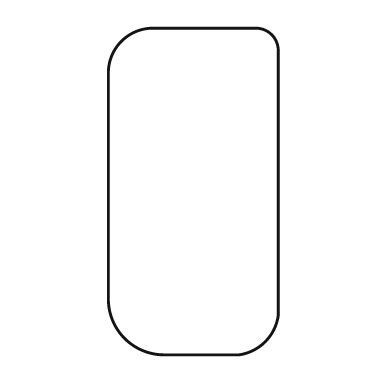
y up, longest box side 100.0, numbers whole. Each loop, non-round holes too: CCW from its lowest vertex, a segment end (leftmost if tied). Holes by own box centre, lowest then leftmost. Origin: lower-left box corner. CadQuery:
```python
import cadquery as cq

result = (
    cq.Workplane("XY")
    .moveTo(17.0, 0.0)
    .lineTo(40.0, 0.0)
    .threePointArc((48.0, 4.0), (52.0, 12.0))
    .lineTo(52.0, 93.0)
    .threePointArc((50.0, 98.0), (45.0, 100.0))
    .lineTo(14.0, 100.0)
    .threePointArc((4.0, 96.0), (0.0, 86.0))
    .lineTo(0.0, 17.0)
    .threePointArc((5.0, 5.0), (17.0, 0.0))
    .close()
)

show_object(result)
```